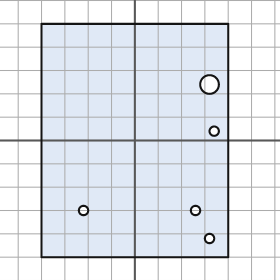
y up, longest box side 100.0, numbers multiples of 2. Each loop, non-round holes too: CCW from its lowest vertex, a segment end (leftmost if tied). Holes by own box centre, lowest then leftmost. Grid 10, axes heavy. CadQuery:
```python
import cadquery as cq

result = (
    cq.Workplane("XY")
    .moveTo(-40.0, -50.0)
    .lineTo(40.0, -50.0)
    .lineTo(40.0, 50.0)
    .lineTo(-40.0, 50.0)
    .close()
    .moveTo(32.0, -42.0)
    .circle(2.0)
    .moveTo(-22.0, -30.0)
    .circle(2.0)
    .moveTo(26.0, -30.0)
    .circle(2.0)
    .moveTo(34.0, 4.0)
    .circle(2.0)
    .moveTo(32.0, 24.0)
    .circle(4.0)
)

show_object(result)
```